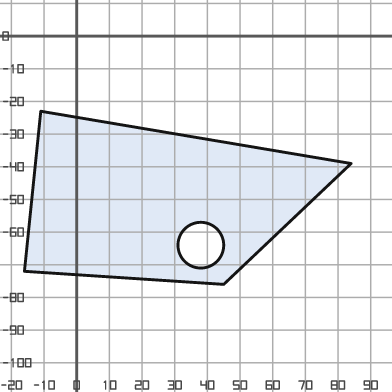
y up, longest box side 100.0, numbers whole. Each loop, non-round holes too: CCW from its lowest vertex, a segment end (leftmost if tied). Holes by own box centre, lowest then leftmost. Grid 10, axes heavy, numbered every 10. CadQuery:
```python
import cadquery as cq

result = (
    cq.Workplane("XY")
    .moveTo(45.0, -76.0)
    .lineTo(84.0, -39.0)
    .lineTo(-11.0, -23.0)
    .lineTo(-16.0, -72.0)
    .close()
    .moveTo(38.0, -64.0)
    .circle(7.0)
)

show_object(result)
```